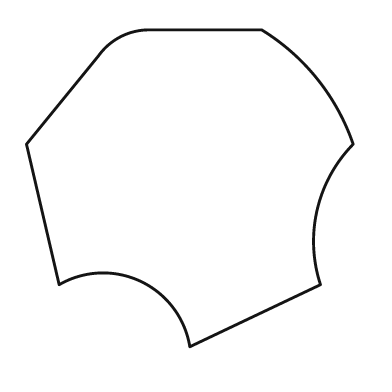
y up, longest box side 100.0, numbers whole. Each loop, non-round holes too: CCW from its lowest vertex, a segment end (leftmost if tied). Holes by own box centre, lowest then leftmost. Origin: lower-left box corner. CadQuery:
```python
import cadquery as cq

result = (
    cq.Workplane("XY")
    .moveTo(50.0, 0.0)
    .lineTo(90.0, 19.0)
    .threePointArc((89.0, 42.0), (100.0, 62.0))
    .threePointArc((89.0, 82.0), (72.0, 97.0))
    .lineTo(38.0, 97.0)
    .threePointArc((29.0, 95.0), (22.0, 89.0))
    .lineTo(0.0, 62.0)
    .lineTo(10.0, 19.0)
    .threePointArc((35.0, 20.0), (50.0, 0.0))
    .close()
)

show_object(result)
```